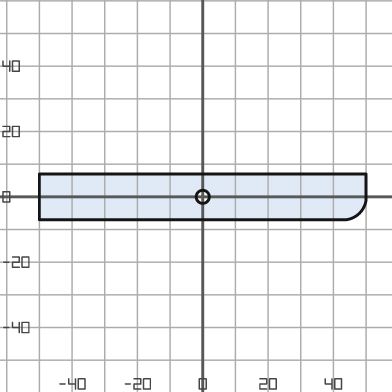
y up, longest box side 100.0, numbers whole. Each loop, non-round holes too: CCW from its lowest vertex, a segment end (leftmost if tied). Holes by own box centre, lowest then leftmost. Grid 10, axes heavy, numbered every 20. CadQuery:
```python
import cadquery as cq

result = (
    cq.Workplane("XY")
    .moveTo(-50.0, -7.0)
    .lineTo(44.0, -7.0)
    .threePointArc((48.0, -5.0), (50.0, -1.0))
    .lineTo(50.0, 7.0)
    .lineTo(-50.0, 7.0)
    .close()
    .moveTo(0.0, 0.0)
    .circle(2.0)
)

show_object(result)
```